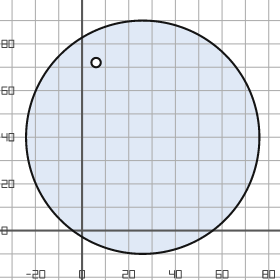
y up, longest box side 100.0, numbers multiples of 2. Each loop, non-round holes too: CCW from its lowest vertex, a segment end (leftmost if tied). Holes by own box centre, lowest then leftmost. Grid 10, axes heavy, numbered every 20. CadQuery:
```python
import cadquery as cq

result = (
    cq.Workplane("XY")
    .moveTo(26.0, 40.0)
    .circle(50.0)
    .moveTo(6.0, 72.0)
    .circle(2.0)
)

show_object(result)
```